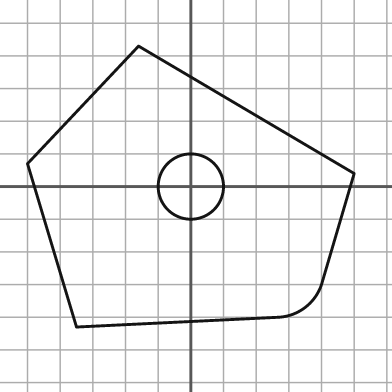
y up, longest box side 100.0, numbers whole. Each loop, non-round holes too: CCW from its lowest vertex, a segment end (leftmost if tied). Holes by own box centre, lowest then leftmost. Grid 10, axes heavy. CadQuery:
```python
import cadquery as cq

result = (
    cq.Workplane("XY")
    .moveTo(-35.0, -43.0)
    .lineTo(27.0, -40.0)
    .threePointArc((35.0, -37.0), (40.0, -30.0))
    .lineTo(50.0, 4.0)
    .lineTo(-16.0, 43.0)
    .lineTo(-50.0, 7.0)
    .close()
    .moveTo(0.0, 0.0)
    .circle(10.0)
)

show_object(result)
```